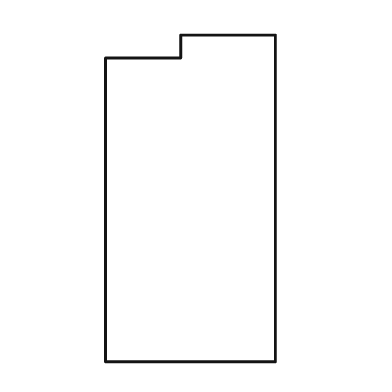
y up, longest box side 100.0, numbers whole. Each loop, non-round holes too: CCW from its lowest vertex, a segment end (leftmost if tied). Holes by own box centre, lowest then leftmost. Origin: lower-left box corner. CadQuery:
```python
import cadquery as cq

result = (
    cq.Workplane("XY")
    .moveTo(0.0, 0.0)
    .lineTo(52.0, 0.0)
    .lineTo(52.0, 100.0)
    .lineTo(23.0, 100.0)
    .lineTo(23.0, 93.0)
    .lineTo(0.0, 93.0)
    .close()
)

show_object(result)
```